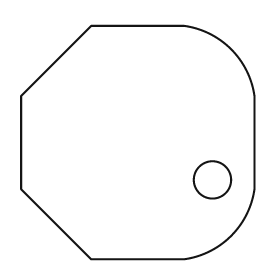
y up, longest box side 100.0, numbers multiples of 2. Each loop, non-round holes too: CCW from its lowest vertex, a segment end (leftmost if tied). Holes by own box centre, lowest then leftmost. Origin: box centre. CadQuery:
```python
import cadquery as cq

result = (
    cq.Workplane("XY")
    .moveTo(-20.0, -50.0)
    .lineTo(20.0, -50.0)
    .threePointArc((40.0, -40.0), (50.0, -20.0))
    .lineTo(50.0, 20.0)
    .threePointArc((40.0, 40.0), (20.0, 50.0))
    .lineTo(-20.0, 50.0)
    .lineTo(-50.0, 20.0)
    .lineTo(-50.0, -20.0)
    .close()
    .moveTo(32.0, -16.0)
    .circle(8.0)
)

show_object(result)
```